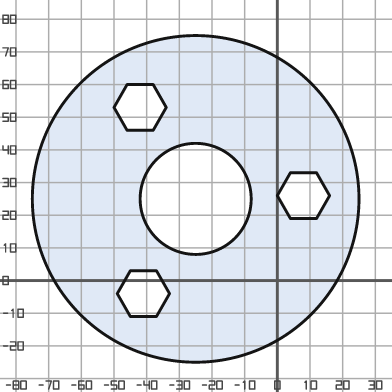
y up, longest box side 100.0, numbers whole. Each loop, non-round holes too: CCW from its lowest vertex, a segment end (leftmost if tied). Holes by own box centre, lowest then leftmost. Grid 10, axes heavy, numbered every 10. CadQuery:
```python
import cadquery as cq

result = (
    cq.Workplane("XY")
    .moveTo(-25.0, 25.0)
    .circle(50.0)
    .moveTo(-45.0, -11.0)
    .lineTo(-37.0, -11.0)
    .lineTo(-33.0, -4.0)
    .lineTo(-37.0, 3.0)
    .lineTo(-45.0, 3.0)
    .lineTo(-49.0, -4.0)
    .close()
    .moveTo(-25.0, 25.0)
    .circle(17.0)
    .moveTo(4.0, 19.0)
    .lineTo(12.0, 19.0)
    .lineTo(16.0, 26.0)
    .lineTo(12.0, 33.0)
    .lineTo(4.0, 33.0)
    .lineTo(0.0, 26.0)
    .close()
    .moveTo(-46.0, 46.0)
    .lineTo(-38.0, 46.0)
    .lineTo(-34.0, 53.0)
    .lineTo(-38.0, 60.0)
    .lineTo(-46.0, 60.0)
    .lineTo(-50.0, 53.0)
    .close()
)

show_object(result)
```